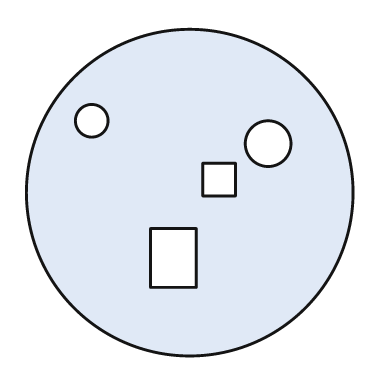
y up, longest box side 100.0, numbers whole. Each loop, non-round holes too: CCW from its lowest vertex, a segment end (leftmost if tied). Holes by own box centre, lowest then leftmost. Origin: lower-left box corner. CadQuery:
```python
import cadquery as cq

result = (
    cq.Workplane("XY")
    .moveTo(50.0, 50.0)
    .circle(50.0)
    .moveTo(38.0, 21.0)
    .lineTo(52.0, 21.0)
    .lineTo(52.0, 39.0)
    .lineTo(38.0, 39.0)
    .close()
    .moveTo(54.0, 49.0)
    .lineTo(64.0, 49.0)
    .lineTo(64.0, 59.0)
    .lineTo(54.0, 59.0)
    .close()
    .moveTo(74.0, 65.0)
    .circle(7.0)
    .moveTo(20.0, 72.0)
    .circle(5.0)
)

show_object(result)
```